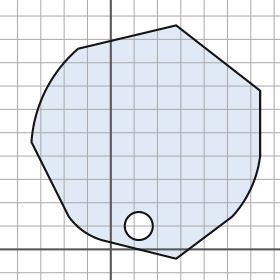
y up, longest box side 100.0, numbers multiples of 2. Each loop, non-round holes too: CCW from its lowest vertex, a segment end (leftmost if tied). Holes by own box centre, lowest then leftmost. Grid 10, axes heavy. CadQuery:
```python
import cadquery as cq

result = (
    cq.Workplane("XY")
    .moveTo(28.0, -4.0)
    .lineTo(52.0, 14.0)
    .threePointArc((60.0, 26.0), (64.0, 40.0))
    .lineTo(64.0, 68.0)
    .lineTo(28.0, 96.0)
    .lineTo(-14.0, 86.0)
    .threePointArc((-28.0, 68.0), (-34.0, 46.0))
    .lineTo(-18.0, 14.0)
    .threePointArc((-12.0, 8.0), (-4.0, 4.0))
    .close()
    .moveTo(12.0, 10.0)
    .circle(6.0)
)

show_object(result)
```